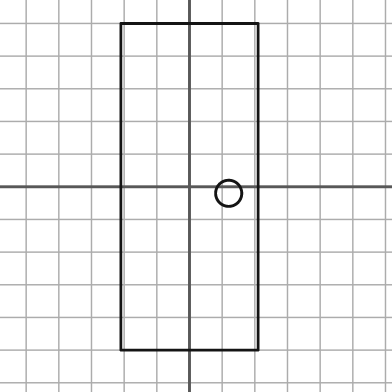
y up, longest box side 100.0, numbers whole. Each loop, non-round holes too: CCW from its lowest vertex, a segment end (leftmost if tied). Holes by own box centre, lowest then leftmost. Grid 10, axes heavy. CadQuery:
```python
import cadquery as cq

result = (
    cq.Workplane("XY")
    .moveTo(-21.0, -50.0)
    .lineTo(21.0, -50.0)
    .lineTo(21.0, 50.0)
    .lineTo(-21.0, 50.0)
    .close()
    .moveTo(12.0, -2.0)
    .circle(4.0)
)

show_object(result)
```